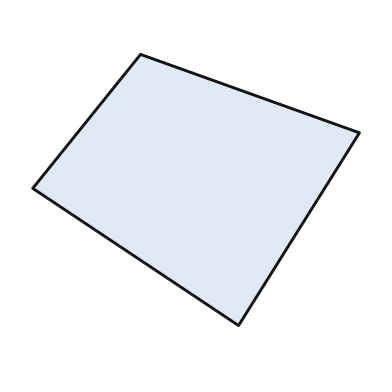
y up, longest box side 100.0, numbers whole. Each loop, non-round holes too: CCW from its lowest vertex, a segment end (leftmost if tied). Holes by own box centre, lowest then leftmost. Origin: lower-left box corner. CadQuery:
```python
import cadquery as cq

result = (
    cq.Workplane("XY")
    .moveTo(63.0, 0.0)
    .lineTo(100.0, 59.0)
    .lineTo(33.0, 83.0)
    .lineTo(0.0, 42.0)
    .close()
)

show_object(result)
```